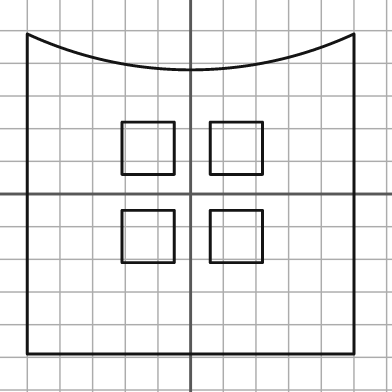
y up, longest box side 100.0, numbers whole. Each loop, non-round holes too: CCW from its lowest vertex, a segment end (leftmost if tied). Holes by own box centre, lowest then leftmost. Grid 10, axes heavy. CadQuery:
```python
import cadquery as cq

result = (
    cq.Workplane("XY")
    .moveTo(-50.0, -49.0)
    .lineTo(50.0, -49.0)
    .lineTo(50.0, 49.0)
    .threePointArc((0.0, 38.0), (-50.0, 49.0))
    .close()
    .moveTo(-21.0, -21.0)
    .lineTo(-5.0, -21.0)
    .lineTo(-5.0, -5.0)
    .lineTo(-21.0, -5.0)
    .close()
    .moveTo(6.0, -21.0)
    .lineTo(22.0, -21.0)
    .lineTo(22.0, -5.0)
    .lineTo(6.0, -5.0)
    .close()
    .moveTo(-21.0, 6.0)
    .lineTo(-5.0, 6.0)
    .lineTo(-5.0, 22.0)
    .lineTo(-21.0, 22.0)
    .close()
    .moveTo(6.0, 6.0)
    .lineTo(22.0, 6.0)
    .lineTo(22.0, 22.0)
    .lineTo(6.0, 22.0)
    .close()
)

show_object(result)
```